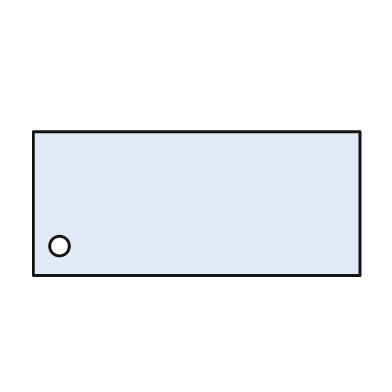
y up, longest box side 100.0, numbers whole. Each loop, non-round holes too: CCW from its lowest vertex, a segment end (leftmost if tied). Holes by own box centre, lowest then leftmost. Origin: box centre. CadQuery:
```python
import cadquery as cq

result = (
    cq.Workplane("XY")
    .moveTo(-50.0, -22.0)
    .lineTo(50.0, -22.0)
    .lineTo(50.0, 22.0)
    .lineTo(-50.0, 22.0)
    .close()
    .moveTo(-42.0, -13.0)
    .circle(3.0)
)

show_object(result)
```